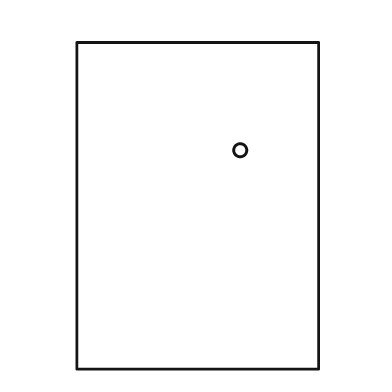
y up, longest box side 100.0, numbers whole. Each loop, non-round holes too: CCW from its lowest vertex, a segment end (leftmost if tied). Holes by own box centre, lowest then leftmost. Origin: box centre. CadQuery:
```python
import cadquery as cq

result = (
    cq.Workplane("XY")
    .moveTo(-37.0, -50.0)
    .lineTo(37.0, -50.0)
    .lineTo(37.0, 50.0)
    .lineTo(-37.0, 50.0)
    .close()
    .moveTo(13.0, 17.0)
    .circle(2.0)
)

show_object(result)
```